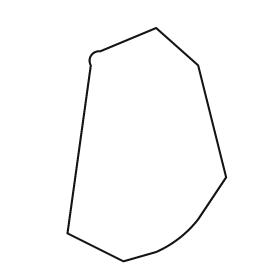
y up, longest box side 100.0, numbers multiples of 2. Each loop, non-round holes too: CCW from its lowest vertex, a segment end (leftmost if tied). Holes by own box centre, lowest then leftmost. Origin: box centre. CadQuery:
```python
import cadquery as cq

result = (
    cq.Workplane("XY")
    .moveTo(-10.0, -50.0)
    .lineTo(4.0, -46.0)
    .threePointArc((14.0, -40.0), (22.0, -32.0))
    .lineTo(34.0, -14.0)
    .lineTo(22.0, 34.0)
    .lineTo(4.0, 50.0)
    .lineTo(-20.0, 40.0)
    .threePointArc((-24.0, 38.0), (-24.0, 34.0))
    .lineTo(-34.0, -38.0)
    .close()
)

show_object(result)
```